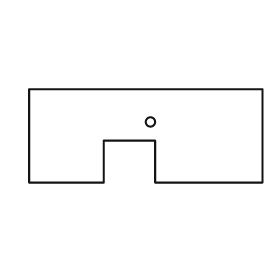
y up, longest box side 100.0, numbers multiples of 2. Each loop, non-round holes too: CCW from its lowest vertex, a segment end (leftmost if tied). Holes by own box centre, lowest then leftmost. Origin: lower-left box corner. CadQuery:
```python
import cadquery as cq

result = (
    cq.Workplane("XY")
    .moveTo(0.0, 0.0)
    .lineTo(32.0, 0.0)
    .lineTo(32.0, 18.0)
    .lineTo(54.0, 18.0)
    .lineTo(54.0, 0.0)
    .lineTo(100.0, 0.0)
    .lineTo(100.0, 40.0)
    .lineTo(0.0, 40.0)
    .close()
    .moveTo(52.0, 26.0)
    .circle(2.0)
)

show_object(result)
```